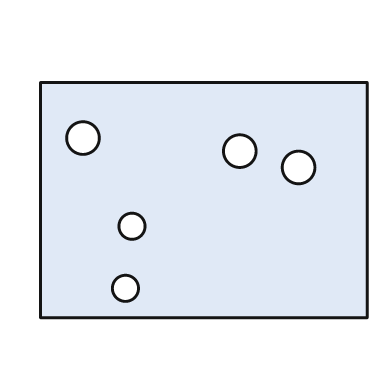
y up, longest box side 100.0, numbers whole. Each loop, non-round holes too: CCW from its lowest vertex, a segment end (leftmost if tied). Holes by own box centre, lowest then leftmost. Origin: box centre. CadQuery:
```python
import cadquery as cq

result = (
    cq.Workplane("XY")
    .moveTo(-50.0, -36.0)
    .lineTo(50.0, -36.0)
    .lineTo(50.0, 36.0)
    .lineTo(-50.0, 36.0)
    .close()
    .moveTo(-24.0, -27.0)
    .circle(4.0)
    .moveTo(-22.0, -8.0)
    .circle(4.0)
    .moveTo(29.0, 10.0)
    .circle(5.0)
    .moveTo(11.0, 15.0)
    .circle(5.0)
    .moveTo(-37.0, 19.0)
    .circle(5.0)
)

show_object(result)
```